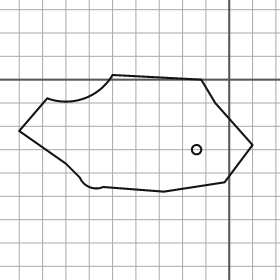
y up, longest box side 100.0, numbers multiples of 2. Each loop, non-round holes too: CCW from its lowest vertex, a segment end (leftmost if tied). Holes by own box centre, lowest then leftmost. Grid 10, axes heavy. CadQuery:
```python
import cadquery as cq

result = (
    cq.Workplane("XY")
    .moveTo(-28.0, -48.0)
    .lineTo(-2.0, -44.0)
    .lineTo(10.0, -28.0)
    .lineTo(-6.0, -10.0)
    .lineTo(-12.0, 0.0)
    .lineTo(-50.0, 2.0)
    .threePointArc((-62.0, -8.0), (-78.0, -8.0))
    .lineTo(-90.0, -22.0)
    .lineTo(-70.0, -36.0)
    .lineTo(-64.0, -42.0)
    .threePointArc((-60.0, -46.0), (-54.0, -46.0))
    .close()
    .moveTo(-14.0, -30.0)
    .circle(2.0)
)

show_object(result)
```